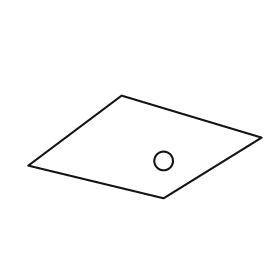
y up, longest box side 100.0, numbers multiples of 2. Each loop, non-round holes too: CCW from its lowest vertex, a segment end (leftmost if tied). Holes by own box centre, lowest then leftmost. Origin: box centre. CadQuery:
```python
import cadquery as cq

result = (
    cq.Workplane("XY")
    .moveTo(8.0, -22.0)
    .lineTo(50.0, 4.0)
    .lineTo(-10.0, 22.0)
    .lineTo(-50.0, -8.0)
    .close()
    .moveTo(8.0, -6.0)
    .circle(4.0)
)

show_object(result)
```